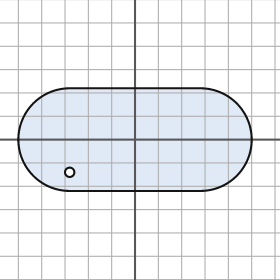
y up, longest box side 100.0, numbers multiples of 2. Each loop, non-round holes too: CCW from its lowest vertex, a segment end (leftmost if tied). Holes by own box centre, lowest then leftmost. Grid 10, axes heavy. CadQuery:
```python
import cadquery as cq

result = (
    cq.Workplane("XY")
    .moveTo(-28.0, -22.0)
    .lineTo(28.0, -22.0)
    .threePointArc((50.0, 0.0), (28.0, 22.0))
    .lineTo(-28.0, 22.0)
    .threePointArc((-50.0, 0.0), (-28.0, -22.0))
    .close()
    .moveTo(-28.0, -14.0)
    .circle(2.0)
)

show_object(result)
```